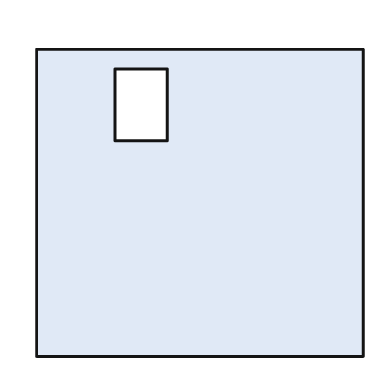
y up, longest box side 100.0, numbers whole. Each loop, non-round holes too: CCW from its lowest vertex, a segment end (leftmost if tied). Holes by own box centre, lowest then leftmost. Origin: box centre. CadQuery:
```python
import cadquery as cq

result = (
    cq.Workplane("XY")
    .moveTo(-50.0, -47.0)
    .lineTo(50.0, -47.0)
    .lineTo(50.0, 47.0)
    .lineTo(-50.0, 47.0)
    .close()
    .moveTo(-26.0, 19.0)
    .lineTo(-10.0, 19.0)
    .lineTo(-10.0, 41.0)
    .lineTo(-26.0, 41.0)
    .close()
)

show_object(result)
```